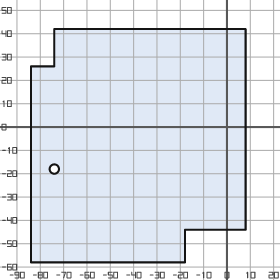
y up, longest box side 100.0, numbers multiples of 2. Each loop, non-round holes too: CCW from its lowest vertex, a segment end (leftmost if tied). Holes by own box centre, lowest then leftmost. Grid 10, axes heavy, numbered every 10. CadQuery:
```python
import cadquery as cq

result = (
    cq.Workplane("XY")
    .moveTo(-84.0, -58.0)
    .lineTo(-18.0, -58.0)
    .lineTo(-18.0, -44.0)
    .lineTo(8.0, -44.0)
    .lineTo(8.0, 42.0)
    .lineTo(-74.0, 42.0)
    .lineTo(-74.0, 26.0)
    .lineTo(-84.0, 26.0)
    .close()
    .moveTo(-74.0, -18.0)
    .circle(2.0)
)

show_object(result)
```